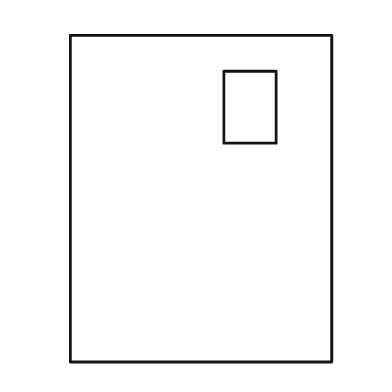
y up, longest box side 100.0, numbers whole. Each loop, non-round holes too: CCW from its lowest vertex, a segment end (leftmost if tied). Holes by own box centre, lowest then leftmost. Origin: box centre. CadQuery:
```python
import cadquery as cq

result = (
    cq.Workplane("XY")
    .moveTo(-40.0, -50.0)
    .lineTo(40.0, -50.0)
    .lineTo(40.0, 50.0)
    .lineTo(-40.0, 50.0)
    .close()
    .moveTo(7.0, 17.0)
    .lineTo(23.0, 17.0)
    .lineTo(23.0, 39.0)
    .lineTo(7.0, 39.0)
    .close()
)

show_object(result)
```